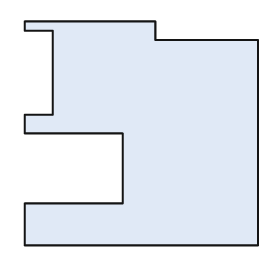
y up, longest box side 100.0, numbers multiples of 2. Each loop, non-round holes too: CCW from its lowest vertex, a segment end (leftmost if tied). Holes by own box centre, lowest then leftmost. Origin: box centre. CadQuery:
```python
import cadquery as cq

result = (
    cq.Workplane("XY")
    .moveTo(-50.0, -48.0)
    .lineTo(50.0, -48.0)
    .lineTo(50.0, 40.0)
    .lineTo(6.0, 40.0)
    .lineTo(6.0, 48.0)
    .lineTo(-50.0, 48.0)
    .lineTo(-50.0, 44.0)
    .lineTo(-38.0, 44.0)
    .lineTo(-38.0, 8.0)
    .lineTo(-50.0, 8.0)
    .lineTo(-50.0, 0.0)
    .lineTo(-8.0, 0.0)
    .lineTo(-8.0, -30.0)
    .lineTo(-50.0, -30.0)
    .close()
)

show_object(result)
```